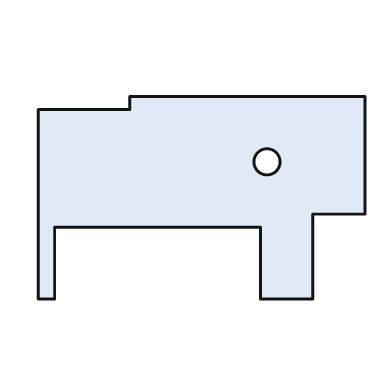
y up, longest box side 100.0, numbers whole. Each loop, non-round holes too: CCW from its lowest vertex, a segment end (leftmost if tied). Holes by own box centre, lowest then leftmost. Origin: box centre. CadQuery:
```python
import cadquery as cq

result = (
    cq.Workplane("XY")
    .moveTo(-50.0, -31.0)
    .lineTo(-45.0, -31.0)
    .lineTo(-45.0, -9.0)
    .lineTo(18.0, -9.0)
    .lineTo(18.0, -31.0)
    .lineTo(34.0, -31.0)
    .lineTo(34.0, -5.0)
    .lineTo(50.0, -5.0)
    .lineTo(50.0, 31.0)
    .lineTo(-22.0, 31.0)
    .lineTo(-22.0, 27.0)
    .lineTo(-50.0, 27.0)
    .close()
    .moveTo(20.0, 11.0)
    .circle(4.0)
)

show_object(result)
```